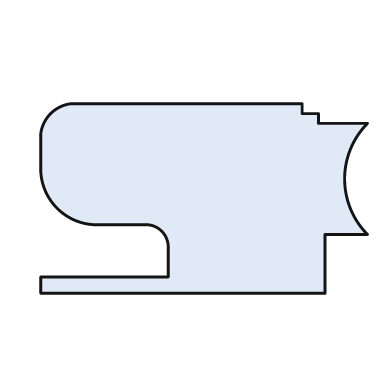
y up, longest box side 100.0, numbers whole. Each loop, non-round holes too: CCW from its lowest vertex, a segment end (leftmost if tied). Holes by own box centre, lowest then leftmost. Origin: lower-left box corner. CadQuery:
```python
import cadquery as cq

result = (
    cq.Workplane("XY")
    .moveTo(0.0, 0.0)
    .lineTo(87.0, 0.0)
    .lineTo(87.0, 18.0)
    .lineTo(100.0, 18.0)
    .threePointArc((93.0, 35.0), (100.0, 52.0))
    .lineTo(85.0, 52.0)
    .lineTo(85.0, 55.0)
    .lineTo(80.0, 55.0)
    .lineTo(80.0, 58.0)
    .lineTo(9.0, 58.0)
    .threePointArc((3.0, 55.0), (0.0, 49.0))
    .lineTo(0.0, 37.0)
    .threePointArc((5.0, 26.0), (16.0, 21.0))
    .lineTo(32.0, 21.0)
    .threePointArc((37.0, 19.0), (39.0, 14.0))
    .lineTo(39.0, 5.0)
    .lineTo(0.0, 5.0)
    .close()
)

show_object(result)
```